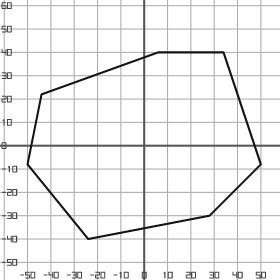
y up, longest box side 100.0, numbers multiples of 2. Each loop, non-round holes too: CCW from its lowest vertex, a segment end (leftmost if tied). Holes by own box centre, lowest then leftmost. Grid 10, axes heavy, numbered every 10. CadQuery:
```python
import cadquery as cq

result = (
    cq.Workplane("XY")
    .moveTo(-24.0, -40.0)
    .lineTo(28.0, -30.0)
    .lineTo(50.0, -8.0)
    .lineTo(34.0, 40.0)
    .lineTo(6.0, 40.0)
    .lineTo(-44.0, 22.0)
    .lineTo(-50.0, -8.0)
    .close()
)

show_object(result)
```